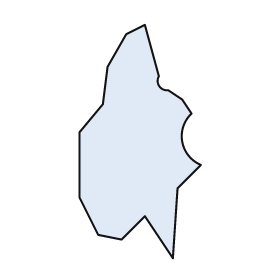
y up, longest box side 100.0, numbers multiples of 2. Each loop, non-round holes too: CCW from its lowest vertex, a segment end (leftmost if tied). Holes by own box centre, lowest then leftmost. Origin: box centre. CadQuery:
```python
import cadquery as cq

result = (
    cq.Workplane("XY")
    .moveTo(14.0, -50.0)
    .lineTo(16.0, -20.0)
    .lineTo(26.0, -10.0)
    .threePointArc((18.0, 0.0), (22.0, 12.0))
    .lineTo(18.0, 18.0)
    .lineTo(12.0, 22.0)
    .threePointArc((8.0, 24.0), (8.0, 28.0))
    .lineTo(2.0, 50.0)
    .lineTo(-6.0, 46.0)
    .lineTo(-14.0, 32.0)
    .lineTo(-16.0, 16.0)
    .lineTo(-26.0, 4.0)
    .lineTo(-26.0, -24.0)
    .lineTo(-18.0, -40.0)
    .lineTo(-8.0, -42.0)
    .lineTo(2.0, -32.0)
    .close()
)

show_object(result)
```